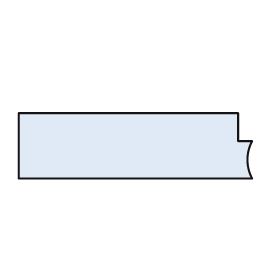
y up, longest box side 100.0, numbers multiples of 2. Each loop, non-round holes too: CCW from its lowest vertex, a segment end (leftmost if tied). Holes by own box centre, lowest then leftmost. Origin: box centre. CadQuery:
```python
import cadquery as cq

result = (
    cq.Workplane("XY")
    .moveTo(-50.0, -14.0)
    .lineTo(50.0, -14.0)
    .threePointArc((48.0, -6.0), (50.0, 2.0))
    .lineTo(44.0, 2.0)
    .lineTo(44.0, 14.0)
    .lineTo(-50.0, 14.0)
    .close()
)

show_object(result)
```